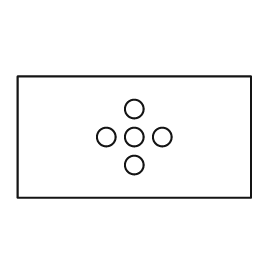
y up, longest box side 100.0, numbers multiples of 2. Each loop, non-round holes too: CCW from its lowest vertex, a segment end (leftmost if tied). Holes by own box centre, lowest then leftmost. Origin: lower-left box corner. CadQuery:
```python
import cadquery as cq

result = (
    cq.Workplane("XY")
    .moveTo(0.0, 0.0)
    .lineTo(100.0, 0.0)
    .lineTo(100.0, 52.0)
    .lineTo(0.0, 52.0)
    .close()
    .moveTo(50.0, 14.0)
    .circle(4.0)
    .moveTo(38.0, 26.0)
    .circle(4.0)
    .moveTo(50.0, 26.0)
    .circle(4.0)
    .moveTo(62.0, 26.0)
    .circle(4.0)
    .moveTo(50.0, 38.0)
    .circle(4.0)
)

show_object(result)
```